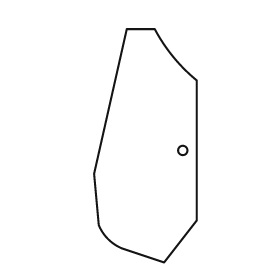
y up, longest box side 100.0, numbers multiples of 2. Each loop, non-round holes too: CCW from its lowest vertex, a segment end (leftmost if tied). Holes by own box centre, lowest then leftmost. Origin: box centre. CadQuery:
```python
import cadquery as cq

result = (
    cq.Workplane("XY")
    .moveTo(8.0, -50.0)
    .lineTo(22.0, -32.0)
    .lineTo(22.0, 28.0)
    .threePointArc((12.0, 38.0), (4.0, 50.0))
    .lineTo(-8.0, 50.0)
    .lineTo(-22.0, -12.0)
    .lineTo(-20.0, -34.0)
    .threePointArc((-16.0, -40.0), (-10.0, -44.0))
    .close()
    .moveTo(16.0, -2.0)
    .circle(2.0)
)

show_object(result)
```